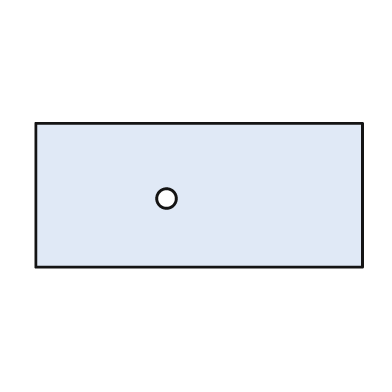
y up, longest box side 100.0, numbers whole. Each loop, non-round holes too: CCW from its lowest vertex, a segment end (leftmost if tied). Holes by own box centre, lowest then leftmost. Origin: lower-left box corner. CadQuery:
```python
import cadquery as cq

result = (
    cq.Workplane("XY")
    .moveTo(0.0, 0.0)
    .lineTo(100.0, 0.0)
    .lineTo(100.0, 44.0)
    .lineTo(0.0, 44.0)
    .close()
    .moveTo(40.0, 21.0)
    .circle(3.0)
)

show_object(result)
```